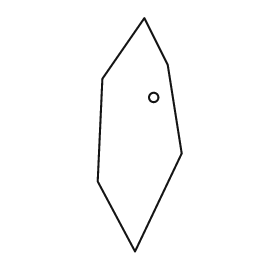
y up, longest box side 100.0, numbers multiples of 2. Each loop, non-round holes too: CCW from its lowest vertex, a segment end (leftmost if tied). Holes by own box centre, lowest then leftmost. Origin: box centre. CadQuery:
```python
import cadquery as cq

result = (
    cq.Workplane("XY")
    .moveTo(-2.0, -50.0)
    .lineTo(18.0, -8.0)
    .lineTo(12.0, 30.0)
    .lineTo(2.0, 50.0)
    .lineTo(-16.0, 24.0)
    .lineTo(-18.0, -20.0)
    .close()
    .moveTo(6.0, 16.0)
    .circle(2.0)
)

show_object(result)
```